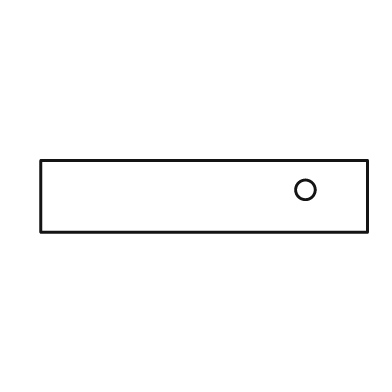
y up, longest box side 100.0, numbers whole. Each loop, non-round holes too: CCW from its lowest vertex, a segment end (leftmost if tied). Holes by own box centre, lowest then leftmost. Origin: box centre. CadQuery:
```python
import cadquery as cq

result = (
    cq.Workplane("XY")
    .moveTo(-50.0, -11.0)
    .lineTo(50.0, -11.0)
    .lineTo(50.0, 11.0)
    .lineTo(-50.0, 11.0)
    .close()
    .moveTo(31.0, 2.0)
    .circle(3.0)
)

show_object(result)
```